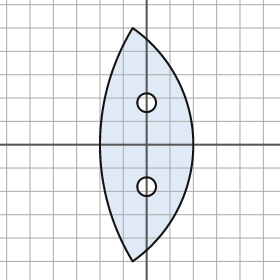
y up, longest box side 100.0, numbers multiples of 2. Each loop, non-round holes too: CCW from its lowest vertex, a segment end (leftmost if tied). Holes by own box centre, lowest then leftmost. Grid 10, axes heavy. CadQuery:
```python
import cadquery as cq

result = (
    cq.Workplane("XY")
    .moveTo(-6.0, -50.0)
    .threePointArc((20.0, 0.0), (-6.0, 50.0))
    .threePointArc((-20.0, 0.0), (-6.0, -50.0))
    .close()
    .moveTo(0.0, -18.0)
    .circle(4.0)
    .moveTo(0.0, 18.0)
    .circle(4.0)
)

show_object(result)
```